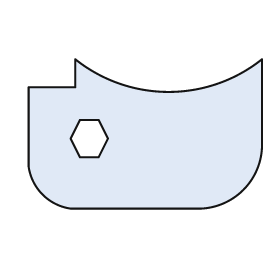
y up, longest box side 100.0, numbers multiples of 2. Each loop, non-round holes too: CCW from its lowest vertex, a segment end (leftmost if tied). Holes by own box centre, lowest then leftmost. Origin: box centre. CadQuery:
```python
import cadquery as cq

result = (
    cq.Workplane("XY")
    .moveTo(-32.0, -32.0)
    .lineTo(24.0, -32.0)
    .threePointArc((42.0, -24.0), (50.0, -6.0))
    .lineTo(50.0, 32.0)
    .threePointArc((10.0, 18.0), (-30.0, 32.0))
    .lineTo(-30.0, 20.0)
    .lineTo(-50.0, 20.0)
    .lineTo(-50.0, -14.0)
    .threePointArc((-44.0, -26.0), (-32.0, -32.0))
    .close()
    .moveTo(-28.0, -10.0)
    .lineTo(-20.0, -10.0)
    .lineTo(-16.0, -2.0)
    .lineTo(-20.0, 6.0)
    .lineTo(-28.0, 6.0)
    .lineTo(-32.0, -2.0)
    .close()
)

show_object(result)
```